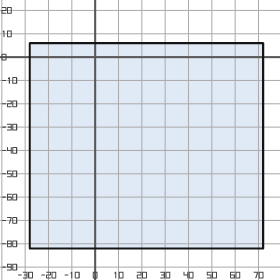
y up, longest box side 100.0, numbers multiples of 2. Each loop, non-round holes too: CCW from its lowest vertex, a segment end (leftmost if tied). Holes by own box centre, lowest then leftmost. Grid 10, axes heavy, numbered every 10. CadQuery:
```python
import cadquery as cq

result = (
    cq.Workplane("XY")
    .moveTo(-28.0, -82.0)
    .lineTo(72.0, -82.0)
    .lineTo(72.0, 6.0)
    .lineTo(-28.0, 6.0)
    .close()
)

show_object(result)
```